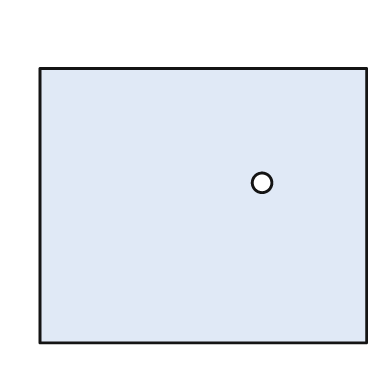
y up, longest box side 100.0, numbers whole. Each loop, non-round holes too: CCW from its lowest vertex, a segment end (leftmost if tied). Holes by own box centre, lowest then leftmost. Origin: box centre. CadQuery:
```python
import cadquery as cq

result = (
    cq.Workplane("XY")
    .moveTo(-50.0, -42.0)
    .lineTo(50.0, -42.0)
    .lineTo(50.0, 42.0)
    .lineTo(-50.0, 42.0)
    .close()
    .moveTo(18.0, 7.0)
    .circle(3.0)
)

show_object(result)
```